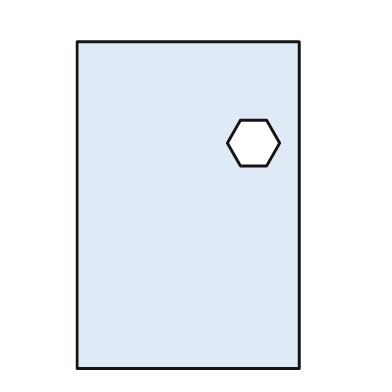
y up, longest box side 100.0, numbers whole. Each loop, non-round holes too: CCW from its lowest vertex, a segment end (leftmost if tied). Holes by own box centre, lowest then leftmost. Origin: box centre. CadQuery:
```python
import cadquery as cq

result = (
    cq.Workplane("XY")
    .moveTo(-34.0, -50.0)
    .lineTo(34.0, -50.0)
    .lineTo(34.0, 50.0)
    .lineTo(-34.0, 50.0)
    .close()
    .moveTo(16.0, 12.0)
    .lineTo(24.0, 12.0)
    .lineTo(28.0, 19.0)
    .lineTo(24.0, 26.0)
    .lineTo(16.0, 26.0)
    .lineTo(12.0, 19.0)
    .close()
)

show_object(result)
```